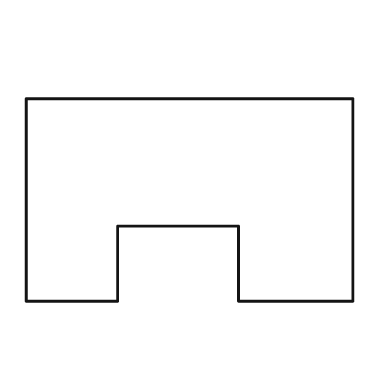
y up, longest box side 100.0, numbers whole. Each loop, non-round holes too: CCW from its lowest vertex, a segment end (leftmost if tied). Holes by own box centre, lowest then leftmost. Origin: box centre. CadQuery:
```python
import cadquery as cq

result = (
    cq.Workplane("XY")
    .moveTo(-50.0, -31.0)
    .lineTo(-22.0, -31.0)
    .lineTo(-22.0, -8.0)
    .lineTo(15.0, -8.0)
    .lineTo(15.0, -31.0)
    .lineTo(50.0, -31.0)
    .lineTo(50.0, 31.0)
    .lineTo(-50.0, 31.0)
    .close()
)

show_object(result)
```